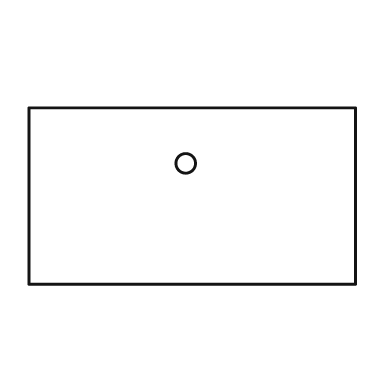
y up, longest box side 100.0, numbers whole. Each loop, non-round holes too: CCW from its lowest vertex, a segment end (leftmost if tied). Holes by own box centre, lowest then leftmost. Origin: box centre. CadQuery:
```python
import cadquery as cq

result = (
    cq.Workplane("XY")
    .moveTo(-50.0, -27.0)
    .lineTo(50.0, -27.0)
    .lineTo(50.0, 27.0)
    .lineTo(-50.0, 27.0)
    .close()
    .moveTo(-2.0, 10.0)
    .circle(3.0)
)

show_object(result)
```